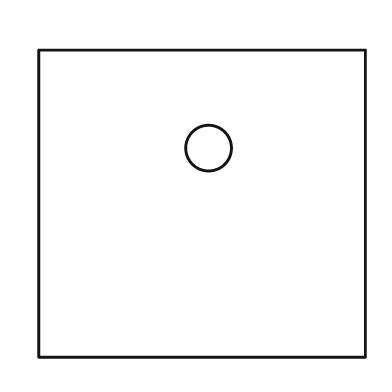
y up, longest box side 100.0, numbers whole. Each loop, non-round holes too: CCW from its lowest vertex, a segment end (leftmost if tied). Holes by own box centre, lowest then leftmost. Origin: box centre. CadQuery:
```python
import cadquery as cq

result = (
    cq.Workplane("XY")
    .moveTo(-50.0, -47.0)
    .lineTo(50.0, -47.0)
    .lineTo(50.0, 47.0)
    .lineTo(-50.0, 47.0)
    .close()
    .moveTo(2.0, 17.0)
    .circle(7.0)
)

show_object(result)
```